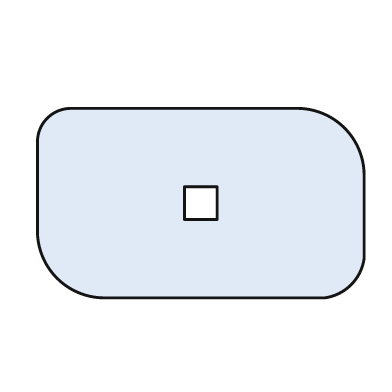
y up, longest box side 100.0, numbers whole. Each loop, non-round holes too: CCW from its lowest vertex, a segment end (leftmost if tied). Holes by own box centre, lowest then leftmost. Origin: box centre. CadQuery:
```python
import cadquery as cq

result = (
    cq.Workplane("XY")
    .moveTo(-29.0, -29.0)
    .lineTo(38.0, -29.0)
    .threePointArc((46.0, -25.0), (50.0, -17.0))
    .lineTo(50.0, 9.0)
    .threePointArc((44.0, 23.0), (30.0, 29.0))
    .lineTo(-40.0, 29.0)
    .threePointArc((-47.0, 26.0), (-50.0, 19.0))
    .lineTo(-50.0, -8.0)
    .threePointArc((-44.0, -23.0), (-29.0, -29.0))
    .close()
    .moveTo(-5.0, -5.0)
    .lineTo(5.0, -5.0)
    .lineTo(5.0, 5.0)
    .lineTo(-5.0, 5.0)
    .close()
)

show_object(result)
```